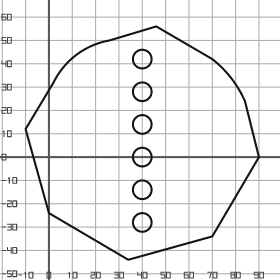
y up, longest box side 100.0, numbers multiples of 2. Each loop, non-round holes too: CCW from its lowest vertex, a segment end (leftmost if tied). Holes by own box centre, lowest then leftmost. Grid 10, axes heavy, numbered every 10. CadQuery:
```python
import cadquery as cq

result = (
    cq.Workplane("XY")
    .moveTo(34.0, -44.0)
    .lineTo(70.0, -34.0)
    .lineTo(90.0, 0.0)
    .lineTo(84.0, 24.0)
    .threePointArc((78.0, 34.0), (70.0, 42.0))
    .lineTo(46.0, 56.0)
    .lineTo(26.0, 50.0)
    .threePointArc((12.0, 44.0), (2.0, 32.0))
    .lineTo(-10.0, 12.0)
    .lineTo(0.0, -24.0)
    .close()
    .moveTo(40.0, -28.0)
    .circle(4.0)
    .moveTo(40.0, -14.0)
    .circle(4.0)
    .moveTo(40.0, 0.0)
    .circle(4.0)
    .moveTo(40.0, 14.0)
    .circle(4.0)
    .moveTo(40.0, 28.0)
    .circle(4.0)
    .moveTo(40.0, 42.0)
    .circle(4.0)
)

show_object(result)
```